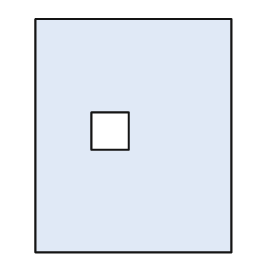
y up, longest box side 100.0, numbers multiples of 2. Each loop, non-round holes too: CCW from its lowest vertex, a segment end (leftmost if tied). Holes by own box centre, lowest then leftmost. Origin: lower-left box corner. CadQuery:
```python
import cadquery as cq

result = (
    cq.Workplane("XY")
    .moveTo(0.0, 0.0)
    .lineTo(84.0, 0.0)
    .lineTo(84.0, 100.0)
    .lineTo(0.0, 100.0)
    .close()
    .moveTo(24.0, 44.0)
    .lineTo(40.0, 44.0)
    .lineTo(40.0, 60.0)
    .lineTo(24.0, 60.0)
    .close()
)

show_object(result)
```